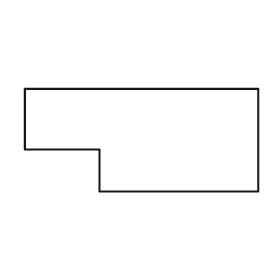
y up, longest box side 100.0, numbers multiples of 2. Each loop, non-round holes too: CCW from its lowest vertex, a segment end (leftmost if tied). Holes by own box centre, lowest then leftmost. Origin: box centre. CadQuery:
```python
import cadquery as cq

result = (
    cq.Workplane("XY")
    .moveTo(-18.0, -22.0)
    .lineTo(50.0, -22.0)
    .lineTo(50.0, 22.0)
    .lineTo(-50.0, 22.0)
    .lineTo(-50.0, -4.0)
    .lineTo(-18.0, -4.0)
    .close()
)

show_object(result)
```